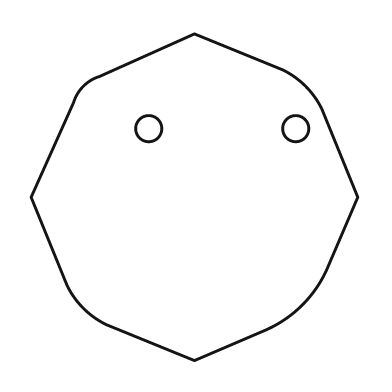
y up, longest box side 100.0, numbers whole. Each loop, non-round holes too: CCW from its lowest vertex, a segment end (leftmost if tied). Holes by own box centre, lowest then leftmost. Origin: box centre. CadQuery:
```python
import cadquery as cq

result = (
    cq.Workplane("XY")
    .moveTo(0.0, -50.0)
    .lineTo(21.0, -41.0)
    .threePointArc((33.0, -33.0), (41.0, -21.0))
    .lineTo(50.0, 0.0)
    .lineTo(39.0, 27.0)
    .threePointArc((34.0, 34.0), (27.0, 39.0))
    .lineTo(0.0, 50.0)
    .lineTo(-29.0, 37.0)
    .threePointArc((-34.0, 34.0), (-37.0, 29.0))
    .lineTo(-50.0, 0.0)
    .lineTo(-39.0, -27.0)
    .threePointArc((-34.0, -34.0), (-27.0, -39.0))
    .close()
    .moveTo(-14.0, 21.0)
    .circle(4.0)
    .moveTo(31.0, 21.0)
    .circle(4.0)
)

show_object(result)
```